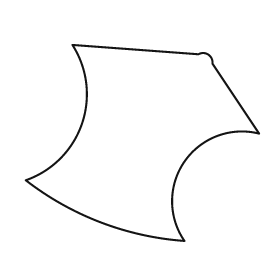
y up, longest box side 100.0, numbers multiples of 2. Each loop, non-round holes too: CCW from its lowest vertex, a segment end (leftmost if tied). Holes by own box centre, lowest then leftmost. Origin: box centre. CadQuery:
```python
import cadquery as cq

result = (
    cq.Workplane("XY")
    .moveTo(18.0, -42.0)
    .threePointArc((18.0, -8.0), (50.0, 4.0))
    .lineTo(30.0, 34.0)
    .threePointArc((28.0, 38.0), (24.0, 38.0))
    .lineTo(-30.0, 42.0)
    .threePointArc((-26.0, 8.0), (-50.0, -16.0))
    .threePointArc((-18.0, -34.0), (18.0, -42.0))
    .close()
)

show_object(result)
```